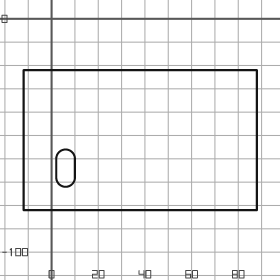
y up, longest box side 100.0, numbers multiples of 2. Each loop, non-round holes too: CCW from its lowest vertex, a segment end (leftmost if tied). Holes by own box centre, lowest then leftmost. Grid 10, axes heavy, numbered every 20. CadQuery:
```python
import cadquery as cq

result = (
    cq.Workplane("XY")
    .moveTo(-12.0, -82.0)
    .lineTo(88.0, -82.0)
    .lineTo(88.0, -22.0)
    .lineTo(-12.0, -22.0)
    .close()
    .moveTo(2.0, -68.0)
    .threePointArc((6.0, -72.0), (10.0, -68.0))
    .lineTo(10.0, -60.0)
    .threePointArc((6.0, -56.0), (2.0, -60.0))
    .close()
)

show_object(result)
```